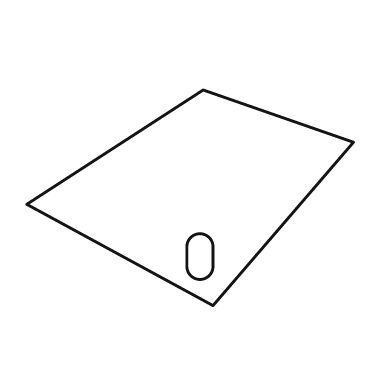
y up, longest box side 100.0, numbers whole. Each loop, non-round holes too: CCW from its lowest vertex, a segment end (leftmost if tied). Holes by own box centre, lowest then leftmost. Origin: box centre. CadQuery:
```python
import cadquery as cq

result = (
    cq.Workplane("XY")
    .moveTo(7.0, -33.0)
    .lineTo(50.0, 17.0)
    .lineTo(4.0, 33.0)
    .lineTo(-50.0, -2.0)
    .close()
    .moveTo(-1.0, -21.0)
    .threePointArc((3.0, -25.0), (7.0, -21.0))
    .lineTo(7.0, -15.0)
    .threePointArc((3.0, -11.0), (-1.0, -15.0))
    .close()
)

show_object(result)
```